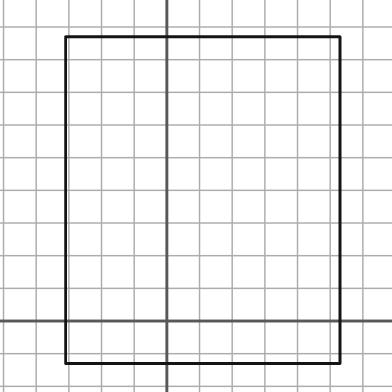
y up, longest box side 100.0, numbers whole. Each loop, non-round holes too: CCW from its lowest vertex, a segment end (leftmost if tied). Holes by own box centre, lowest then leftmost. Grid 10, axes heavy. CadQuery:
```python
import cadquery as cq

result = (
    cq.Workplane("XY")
    .moveTo(-31.0, -13.0)
    .lineTo(53.0, -13.0)
    .lineTo(53.0, 87.0)
    .lineTo(-31.0, 87.0)
    .close()
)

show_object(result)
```